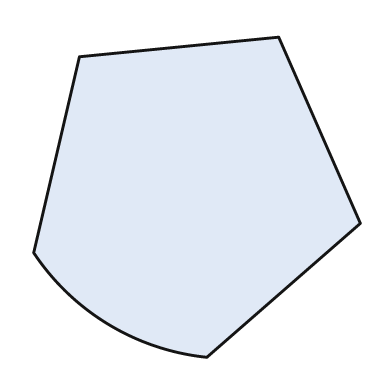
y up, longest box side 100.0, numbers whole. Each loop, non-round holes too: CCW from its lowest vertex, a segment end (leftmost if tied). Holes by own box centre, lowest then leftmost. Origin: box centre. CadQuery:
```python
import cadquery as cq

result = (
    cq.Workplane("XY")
    .moveTo(3.0, -49.0)
    .lineTo(50.0, -8.0)
    .lineTo(25.0, 49.0)
    .lineTo(-36.0, 43.0)
    .lineTo(-50.0, -17.0)
    .threePointArc((-27.0, -39.0), (3.0, -49.0))
    .close()
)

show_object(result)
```